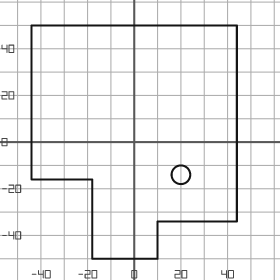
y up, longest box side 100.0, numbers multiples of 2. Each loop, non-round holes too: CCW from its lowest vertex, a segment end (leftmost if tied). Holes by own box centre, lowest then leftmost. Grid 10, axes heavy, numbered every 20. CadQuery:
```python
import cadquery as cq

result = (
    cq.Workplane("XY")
    .moveTo(-18.0, -50.0)
    .lineTo(10.0, -50.0)
    .lineTo(10.0, -34.0)
    .lineTo(44.0, -34.0)
    .lineTo(44.0, 50.0)
    .lineTo(-44.0, 50.0)
    .lineTo(-44.0, -16.0)
    .lineTo(-18.0, -16.0)
    .close()
    .moveTo(20.0, -14.0)
    .circle(4.0)
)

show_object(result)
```